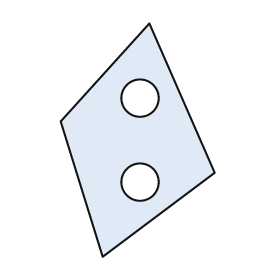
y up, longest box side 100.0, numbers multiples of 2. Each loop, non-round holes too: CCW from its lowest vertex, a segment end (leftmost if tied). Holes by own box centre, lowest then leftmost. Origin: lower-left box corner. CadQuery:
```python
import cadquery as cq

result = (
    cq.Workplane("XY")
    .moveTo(18.0, 0.0)
    .lineTo(66.0, 36.0)
    .lineTo(38.0, 100.0)
    .lineTo(0.0, 58.0)
    .close()
    .moveTo(34.0, 32.0)
    .circle(8.0)
    .moveTo(34.0, 68.0)
    .circle(8.0)
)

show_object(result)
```